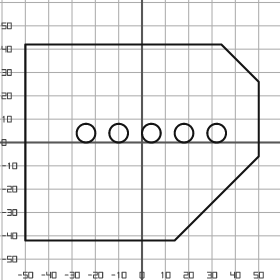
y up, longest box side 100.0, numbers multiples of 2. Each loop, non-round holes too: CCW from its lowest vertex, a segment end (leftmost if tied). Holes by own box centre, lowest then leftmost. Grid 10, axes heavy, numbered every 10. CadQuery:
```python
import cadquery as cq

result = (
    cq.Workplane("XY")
    .moveTo(-50.0, -42.0)
    .lineTo(14.0, -42.0)
    .lineTo(50.0, -6.0)
    .lineTo(50.0, 26.0)
    .lineTo(34.0, 42.0)
    .lineTo(-50.0, 42.0)
    .close()
    .moveTo(-24.0, 4.0)
    .circle(4.0)
    .moveTo(-10.0, 4.0)
    .circle(4.0)
    .moveTo(4.0, 4.0)
    .circle(4.0)
    .moveTo(18.0, 4.0)
    .circle(4.0)
    .moveTo(32.0, 4.0)
    .circle(4.0)
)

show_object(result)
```